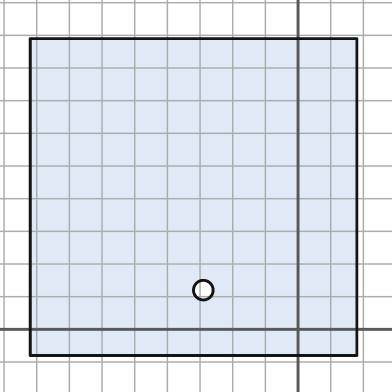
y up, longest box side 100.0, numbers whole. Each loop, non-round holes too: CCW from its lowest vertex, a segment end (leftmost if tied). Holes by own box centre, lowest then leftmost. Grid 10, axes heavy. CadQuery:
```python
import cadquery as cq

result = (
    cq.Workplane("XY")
    .moveTo(-82.0, -8.0)
    .lineTo(18.0, -8.0)
    .lineTo(18.0, 89.0)
    .lineTo(-82.0, 89.0)
    .close()
    .moveTo(-29.0, 12.0)
    .circle(3.0)
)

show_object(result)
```